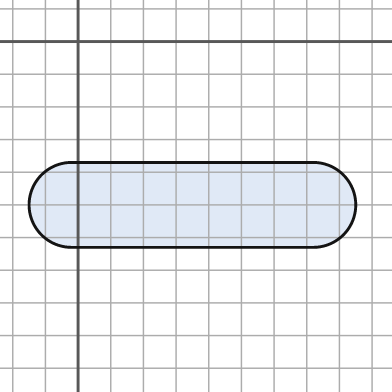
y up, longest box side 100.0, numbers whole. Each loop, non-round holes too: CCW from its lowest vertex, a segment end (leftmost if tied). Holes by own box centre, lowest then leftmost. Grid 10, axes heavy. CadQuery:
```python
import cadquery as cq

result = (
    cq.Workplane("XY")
    .moveTo(-2.0, -63.0)
    .lineTo(72.0, -63.0)
    .threePointArc((85.0, -50.0), (72.0, -37.0))
    .lineTo(-2.0, -37.0)
    .threePointArc((-15.0, -50.0), (-2.0, -63.0))
    .close()
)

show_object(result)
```